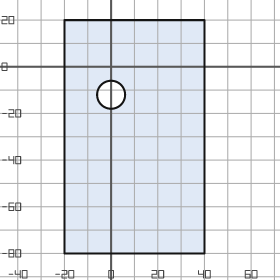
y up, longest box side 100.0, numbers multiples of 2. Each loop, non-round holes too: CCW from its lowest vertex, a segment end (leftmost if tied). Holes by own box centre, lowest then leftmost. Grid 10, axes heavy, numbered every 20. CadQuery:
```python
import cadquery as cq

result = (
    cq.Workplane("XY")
    .moveTo(-20.0, -80.0)
    .lineTo(40.0, -80.0)
    .lineTo(40.0, 20.0)
    .lineTo(-20.0, 20.0)
    .close()
    .moveTo(0.0, -12.0)
    .circle(6.0)
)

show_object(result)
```